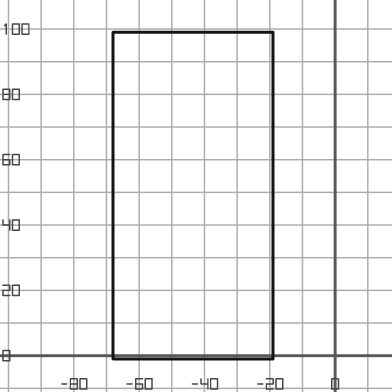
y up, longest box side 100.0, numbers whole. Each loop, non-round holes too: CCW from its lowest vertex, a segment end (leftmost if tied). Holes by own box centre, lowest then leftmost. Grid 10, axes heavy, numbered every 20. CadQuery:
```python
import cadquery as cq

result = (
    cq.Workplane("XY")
    .moveTo(-68.0, -1.0)
    .lineTo(-19.0, -1.0)
    .lineTo(-19.0, 99.0)
    .lineTo(-68.0, 99.0)
    .close()
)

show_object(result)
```